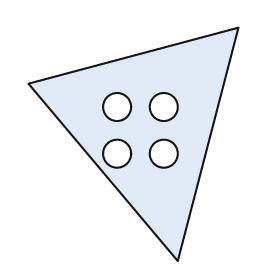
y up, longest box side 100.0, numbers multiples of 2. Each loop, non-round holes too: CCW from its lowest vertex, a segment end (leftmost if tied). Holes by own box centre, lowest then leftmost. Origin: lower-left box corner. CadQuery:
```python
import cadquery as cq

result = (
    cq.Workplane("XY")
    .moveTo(64.0, 0.0)
    .lineTo(90.0, 100.0)
    .lineTo(0.0, 76.0)
    .close()
    .moveTo(38.0, 46.0)
    .circle(6.0)
    .moveTo(58.0, 46.0)
    .circle(6.0)
    .moveTo(38.0, 66.0)
    .circle(6.0)
    .moveTo(58.0, 66.0)
    .circle(6.0)
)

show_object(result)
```